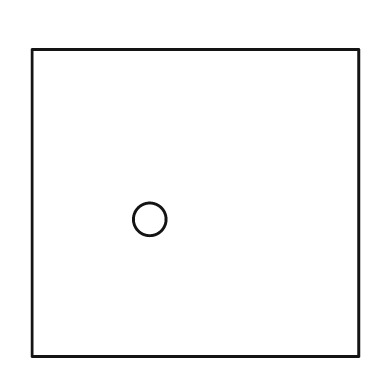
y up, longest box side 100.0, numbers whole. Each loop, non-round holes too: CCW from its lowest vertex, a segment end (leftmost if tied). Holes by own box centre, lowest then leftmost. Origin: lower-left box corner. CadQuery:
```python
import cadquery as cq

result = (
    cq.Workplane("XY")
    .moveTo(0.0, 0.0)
    .lineTo(100.0, 0.0)
    .lineTo(100.0, 94.0)
    .lineTo(0.0, 94.0)
    .close()
    .moveTo(36.0, 42.0)
    .circle(5.0)
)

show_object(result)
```